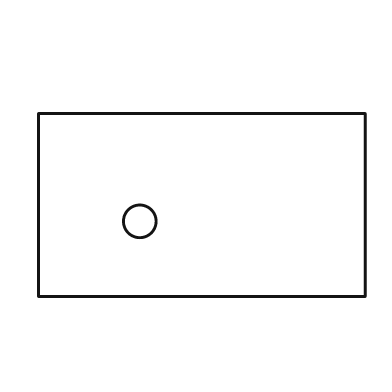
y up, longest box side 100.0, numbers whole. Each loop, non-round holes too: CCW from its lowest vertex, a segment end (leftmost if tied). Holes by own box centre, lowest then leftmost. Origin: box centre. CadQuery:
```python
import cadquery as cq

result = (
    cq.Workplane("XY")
    .moveTo(-50.0, -28.0)
    .lineTo(50.0, -28.0)
    .lineTo(50.0, 28.0)
    .lineTo(-50.0, 28.0)
    .close()
    .moveTo(-19.0, -5.0)
    .circle(5.0)
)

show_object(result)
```